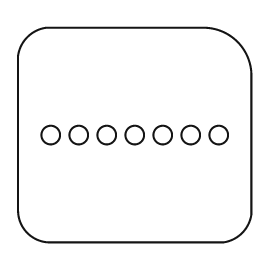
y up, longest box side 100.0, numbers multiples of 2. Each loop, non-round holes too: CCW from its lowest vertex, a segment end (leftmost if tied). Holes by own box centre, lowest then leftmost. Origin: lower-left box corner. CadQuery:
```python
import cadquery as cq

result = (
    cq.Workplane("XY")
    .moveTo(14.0, 0.0)
    .lineTo(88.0, 0.0)
    .threePointArc((96.0, 4.0), (100.0, 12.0))
    .lineTo(100.0, 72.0)
    .threePointArc((94.0, 86.0), (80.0, 92.0))
    .lineTo(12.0, 92.0)
    .threePointArc((4.0, 88.0), (0.0, 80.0))
    .lineTo(0.0, 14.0)
    .threePointArc((4.0, 4.0), (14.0, 0.0))
    .close()
    .moveTo(14.0, 46.0)
    .circle(4.0)
    .moveTo(26.0, 46.0)
    .circle(4.0)
    .moveTo(38.0, 46.0)
    .circle(4.0)
    .moveTo(50.0, 46.0)
    .circle(4.0)
    .moveTo(62.0, 46.0)
    .circle(4.0)
    .moveTo(74.0, 46.0)
    .circle(4.0)
    .moveTo(86.0, 46.0)
    .circle(4.0)
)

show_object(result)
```